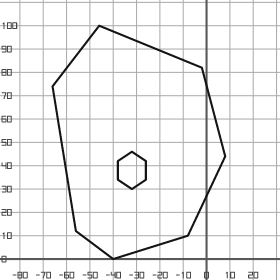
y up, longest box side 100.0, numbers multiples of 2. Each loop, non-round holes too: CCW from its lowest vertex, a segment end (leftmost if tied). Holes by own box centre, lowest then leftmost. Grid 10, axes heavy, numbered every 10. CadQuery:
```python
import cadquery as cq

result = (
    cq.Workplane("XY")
    .moveTo(-40.0, 0.0)
    .lineTo(-8.0, 10.0)
    .lineTo(8.0, 44.0)
    .lineTo(-2.0, 82.0)
    .lineTo(-46.0, 100.0)
    .lineTo(-66.0, 74.0)
    .lineTo(-56.0, 12.0)
    .close()
    .moveTo(-32.0, 30.0)
    .lineTo(-26.0, 34.0)
    .lineTo(-26.0, 42.0)
    .lineTo(-32.0, 46.0)
    .lineTo(-38.0, 42.0)
    .lineTo(-38.0, 34.0)
    .close()
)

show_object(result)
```